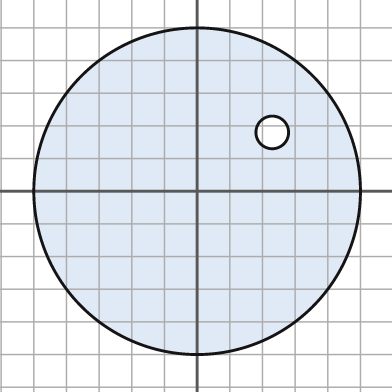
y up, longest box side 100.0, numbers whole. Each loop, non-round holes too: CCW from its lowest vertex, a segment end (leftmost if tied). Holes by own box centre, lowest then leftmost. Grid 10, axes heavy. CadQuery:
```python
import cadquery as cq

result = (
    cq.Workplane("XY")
    .moveTo(0.0, 0.0)
    .circle(50.0)
    .moveTo(23.0, 18.0)
    .circle(5.0)
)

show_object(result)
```